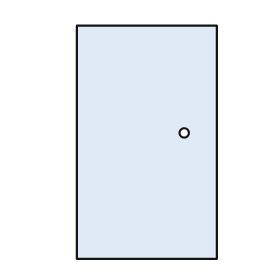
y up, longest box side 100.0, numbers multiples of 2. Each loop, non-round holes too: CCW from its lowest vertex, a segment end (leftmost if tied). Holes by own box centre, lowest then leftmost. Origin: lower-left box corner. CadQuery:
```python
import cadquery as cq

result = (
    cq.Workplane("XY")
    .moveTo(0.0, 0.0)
    .lineTo(60.0, 0.0)
    .lineTo(60.0, 100.0)
    .lineTo(0.0, 100.0)
    .close()
    .moveTo(46.0, 54.0)
    .circle(2.0)
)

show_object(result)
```